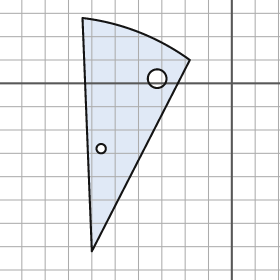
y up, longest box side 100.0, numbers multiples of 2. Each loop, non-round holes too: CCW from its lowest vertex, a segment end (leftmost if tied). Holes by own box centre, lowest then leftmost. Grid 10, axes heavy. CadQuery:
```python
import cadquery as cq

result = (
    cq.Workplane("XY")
    .moveTo(-60.0, -72.0)
    .lineTo(-18.0, 10.0)
    .threePointArc((-40.0, 22.0), (-64.0, 28.0))
    .close()
    .moveTo(-56.0, -28.0)
    .circle(2.0)
    .moveTo(-32.0, 2.0)
    .circle(4.0)
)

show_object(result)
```